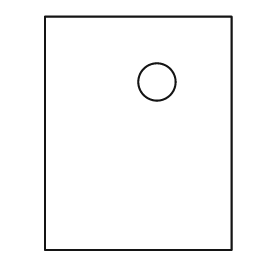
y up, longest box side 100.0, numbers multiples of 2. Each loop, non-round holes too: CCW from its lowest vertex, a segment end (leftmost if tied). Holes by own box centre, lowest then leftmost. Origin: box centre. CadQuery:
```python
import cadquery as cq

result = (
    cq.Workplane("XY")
    .moveTo(-40.0, -50.0)
    .lineTo(40.0, -50.0)
    .lineTo(40.0, 50.0)
    .lineTo(-40.0, 50.0)
    .close()
    .moveTo(8.0, 22.0)
    .circle(8.0)
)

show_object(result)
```